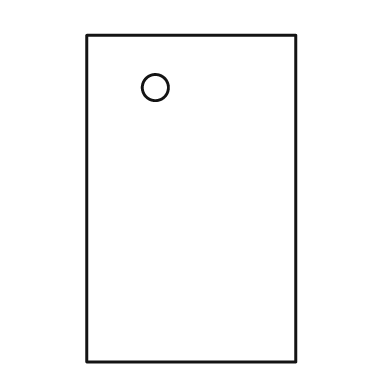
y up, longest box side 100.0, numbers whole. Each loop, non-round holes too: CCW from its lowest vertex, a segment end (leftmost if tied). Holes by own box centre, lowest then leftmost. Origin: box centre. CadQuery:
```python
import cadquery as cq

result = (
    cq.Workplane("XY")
    .moveTo(-32.0, -50.0)
    .lineTo(32.0, -50.0)
    .lineTo(32.0, 50.0)
    .lineTo(-32.0, 50.0)
    .close()
    .moveTo(-11.0, 34.0)
    .circle(4.0)
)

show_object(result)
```